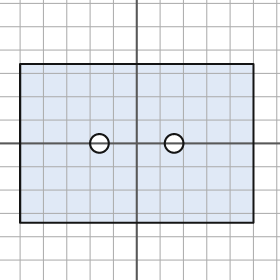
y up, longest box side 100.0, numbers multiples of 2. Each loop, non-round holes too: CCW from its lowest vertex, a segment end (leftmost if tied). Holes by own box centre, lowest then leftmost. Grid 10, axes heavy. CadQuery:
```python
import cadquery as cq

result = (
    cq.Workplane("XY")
    .moveTo(-50.0, -34.0)
    .lineTo(50.0, -34.0)
    .lineTo(50.0, 34.0)
    .lineTo(-50.0, 34.0)
    .close()
    .moveTo(-16.0, 0.0)
    .circle(4.0)
    .moveTo(16.0, 0.0)
    .circle(4.0)
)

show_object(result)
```